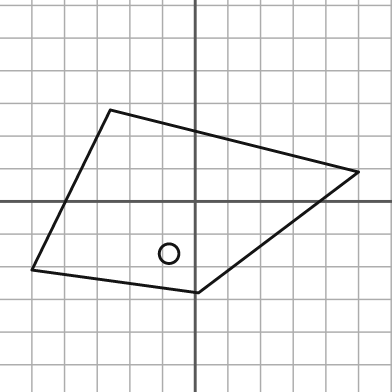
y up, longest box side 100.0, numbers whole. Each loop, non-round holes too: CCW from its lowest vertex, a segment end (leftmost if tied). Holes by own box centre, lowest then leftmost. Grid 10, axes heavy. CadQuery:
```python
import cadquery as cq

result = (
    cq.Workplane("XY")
    .moveTo(1.0, -28.0)
    .lineTo(50.0, 9.0)
    .lineTo(-26.0, 28.0)
    .lineTo(-50.0, -21.0)
    .close()
    .moveTo(-8.0, -16.0)
    .circle(3.0)
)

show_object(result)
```